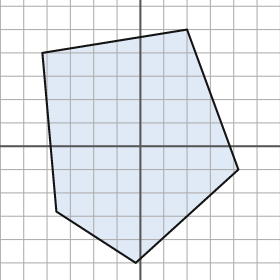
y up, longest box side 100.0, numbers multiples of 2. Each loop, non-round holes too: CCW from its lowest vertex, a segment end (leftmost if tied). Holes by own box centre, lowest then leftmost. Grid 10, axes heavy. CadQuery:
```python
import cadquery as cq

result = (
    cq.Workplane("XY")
    .moveTo(-2.0, -50.0)
    .lineTo(42.0, -10.0)
    .lineTo(20.0, 50.0)
    .lineTo(-42.0, 40.0)
    .lineTo(-36.0, -28.0)
    .close()
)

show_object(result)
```